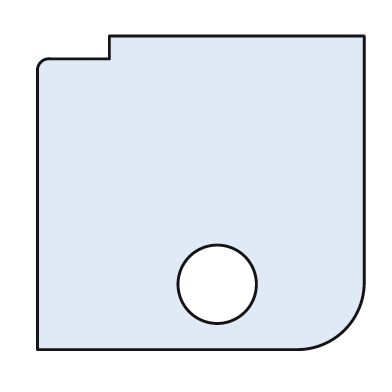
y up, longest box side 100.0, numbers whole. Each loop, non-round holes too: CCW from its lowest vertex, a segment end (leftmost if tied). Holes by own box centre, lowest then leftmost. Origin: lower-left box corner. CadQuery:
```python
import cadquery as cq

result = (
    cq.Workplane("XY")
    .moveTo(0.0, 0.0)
    .lineTo(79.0, 0.0)
    .threePointArc((94.0, 6.0), (100.0, 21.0))
    .lineTo(100.0, 96.0)
    .lineTo(22.0, 96.0)
    .lineTo(22.0, 89.0)
    .lineTo(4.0, 89.0)
    .threePointArc((1.0, 88.0), (0.0, 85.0))
    .close()
    .moveTo(55.0, 20.0)
    .circle(12.0)
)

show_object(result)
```